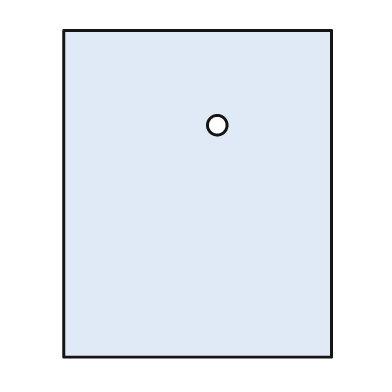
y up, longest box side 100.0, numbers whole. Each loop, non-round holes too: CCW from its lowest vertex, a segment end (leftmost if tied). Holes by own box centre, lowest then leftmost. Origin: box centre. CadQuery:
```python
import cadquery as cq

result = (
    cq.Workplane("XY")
    .moveTo(-41.0, -50.0)
    .lineTo(41.0, -50.0)
    .lineTo(41.0, 50.0)
    .lineTo(-41.0, 50.0)
    .close()
    .moveTo(6.0, 21.0)
    .circle(3.0)
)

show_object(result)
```